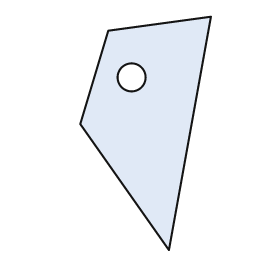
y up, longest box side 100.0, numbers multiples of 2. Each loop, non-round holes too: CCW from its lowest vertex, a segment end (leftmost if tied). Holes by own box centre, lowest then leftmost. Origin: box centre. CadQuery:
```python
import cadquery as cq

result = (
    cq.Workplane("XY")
    .moveTo(10.0, -50.0)
    .lineTo(28.0, 50.0)
    .lineTo(-16.0, 44.0)
    .lineTo(-28.0, 4.0)
    .close()
    .moveTo(-6.0, 24.0)
    .circle(6.0)
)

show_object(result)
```